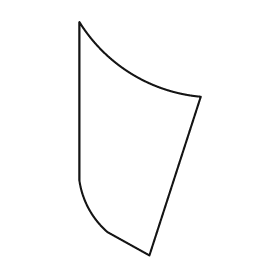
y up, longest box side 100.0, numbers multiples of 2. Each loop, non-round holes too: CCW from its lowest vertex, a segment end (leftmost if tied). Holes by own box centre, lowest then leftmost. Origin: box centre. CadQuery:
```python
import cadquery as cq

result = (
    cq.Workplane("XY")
    .moveTo(4.0, -50.0)
    .lineTo(26.0, 18.0)
    .threePointArc((-4.0, 28.0), (-26.0, 50.0))
    .lineTo(-26.0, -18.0)
    .threePointArc((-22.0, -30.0), (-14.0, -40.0))
    .close()
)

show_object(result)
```